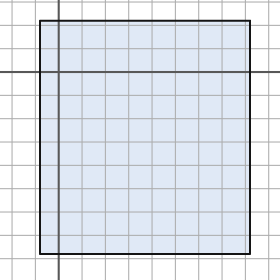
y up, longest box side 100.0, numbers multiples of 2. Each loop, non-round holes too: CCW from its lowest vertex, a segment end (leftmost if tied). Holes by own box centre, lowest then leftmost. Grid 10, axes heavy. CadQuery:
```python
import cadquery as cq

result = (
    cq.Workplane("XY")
    .moveTo(-8.0, -78.0)
    .lineTo(82.0, -78.0)
    .lineTo(82.0, 22.0)
    .lineTo(-8.0, 22.0)
    .close()
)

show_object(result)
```